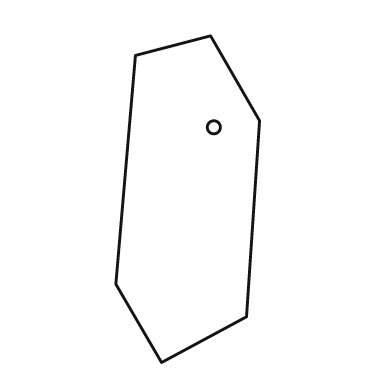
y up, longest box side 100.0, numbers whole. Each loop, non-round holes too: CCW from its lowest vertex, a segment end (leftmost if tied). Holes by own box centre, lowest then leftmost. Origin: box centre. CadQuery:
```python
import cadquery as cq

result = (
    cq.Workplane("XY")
    .moveTo(-8.0, -50.0)
    .lineTo(18.0, -36.0)
    .lineTo(22.0, 24.0)
    .lineTo(7.0, 50.0)
    .lineTo(-16.0, 44.0)
    .lineTo(-22.0, -26.0)
    .close()
    .moveTo(8.0, 22.0)
    .circle(2.0)
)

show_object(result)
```